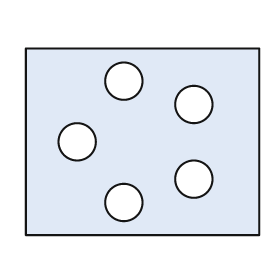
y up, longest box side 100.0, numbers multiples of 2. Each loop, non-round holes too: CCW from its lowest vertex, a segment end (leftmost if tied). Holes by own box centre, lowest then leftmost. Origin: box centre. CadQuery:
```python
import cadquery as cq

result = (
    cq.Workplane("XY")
    .moveTo(-50.0, -40.0)
    .lineTo(50.0, -40.0)
    .lineTo(50.0, 40.0)
    .lineTo(-50.0, 40.0)
    .close()
    .moveTo(-8.0, -26.0)
    .circle(8.0)
    .moveTo(22.0, -16.0)
    .circle(8.0)
    .moveTo(-28.0, 0.0)
    .circle(8.0)
    .moveTo(22.0, 16.0)
    .circle(8.0)
    .moveTo(-8.0, 26.0)
    .circle(8.0)
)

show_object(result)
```